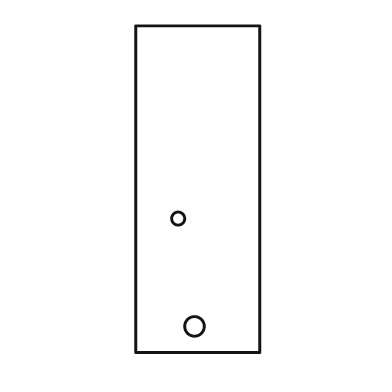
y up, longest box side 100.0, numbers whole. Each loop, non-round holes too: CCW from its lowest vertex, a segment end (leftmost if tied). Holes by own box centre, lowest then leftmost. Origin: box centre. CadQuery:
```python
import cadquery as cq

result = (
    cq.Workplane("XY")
    .moveTo(-19.0, -50.0)
    .lineTo(19.0, -50.0)
    .lineTo(19.0, 50.0)
    .lineTo(-19.0, 50.0)
    .close()
    .moveTo(-1.0, -42.0)
    .circle(3.0)
    .moveTo(-6.0, -9.0)
    .circle(2.0)
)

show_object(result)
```